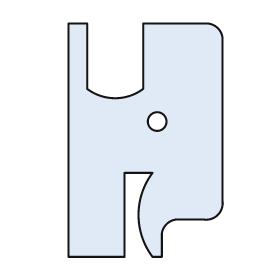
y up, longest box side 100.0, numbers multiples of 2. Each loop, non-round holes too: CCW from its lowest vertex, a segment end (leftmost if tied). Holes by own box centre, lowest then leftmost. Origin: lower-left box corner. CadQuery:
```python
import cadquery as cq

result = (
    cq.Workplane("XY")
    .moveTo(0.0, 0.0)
    .lineTo(24.0, 0.0)
    .lineTo(24.0, 36.0)
    .lineTo(36.0, 36.0)
    .threePointArc((30.0, 18.0), (36.0, 0.0))
    .lineTo(40.0, 0.0)
    .lineTo(40.0, 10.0)
    .threePointArc((42.0, 14.0), (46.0, 16.0))
    .lineTo(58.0, 16.0)
    .threePointArc((64.0, 18.0), (66.0, 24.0))
    .lineTo(66.0, 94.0)
    .threePointArc((64.0, 98.0), (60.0, 100.0))
    .lineTo(32.0, 100.0)
    .lineTo(32.0, 72.0)
    .threePointArc((20.0, 68.0), (8.0, 72.0))
    .lineTo(8.0, 100.0)
    .lineTo(0.0, 100.0)
    .close()
    .moveTo(38.0, 58.0)
    .circle(4.0)
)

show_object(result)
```